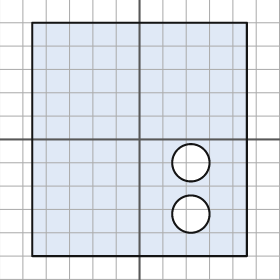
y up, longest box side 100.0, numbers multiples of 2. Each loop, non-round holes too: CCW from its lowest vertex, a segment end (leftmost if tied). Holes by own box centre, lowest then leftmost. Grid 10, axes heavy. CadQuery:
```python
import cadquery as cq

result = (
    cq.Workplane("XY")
    .moveTo(-46.0, -50.0)
    .lineTo(46.0, -50.0)
    .lineTo(46.0, 50.0)
    .lineTo(-46.0, 50.0)
    .close()
    .moveTo(22.0, -32.0)
    .circle(8.0)
    .moveTo(22.0, -10.0)
    .circle(8.0)
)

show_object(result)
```